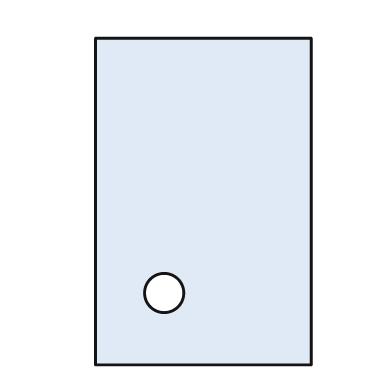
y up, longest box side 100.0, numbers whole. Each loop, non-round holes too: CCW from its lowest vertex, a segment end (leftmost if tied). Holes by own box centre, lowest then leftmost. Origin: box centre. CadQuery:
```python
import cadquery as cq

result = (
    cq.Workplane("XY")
    .moveTo(-33.0, -50.0)
    .lineTo(33.0, -50.0)
    .lineTo(33.0, 50.0)
    .lineTo(-33.0, 50.0)
    .close()
    .moveTo(-12.0, -28.0)
    .circle(6.0)
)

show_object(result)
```